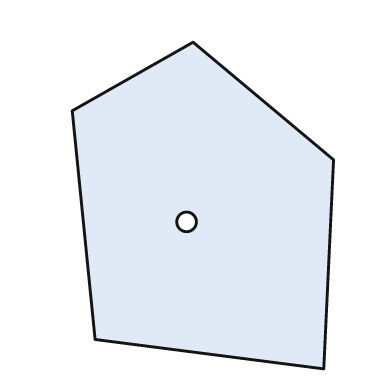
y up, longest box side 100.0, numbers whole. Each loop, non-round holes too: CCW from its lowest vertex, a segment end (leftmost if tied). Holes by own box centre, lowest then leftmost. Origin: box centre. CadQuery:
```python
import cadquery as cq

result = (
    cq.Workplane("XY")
    .moveTo(37.0, -50.0)
    .lineTo(40.0, 14.0)
    .lineTo(-3.0, 50.0)
    .lineTo(-40.0, 29.0)
    .lineTo(-33.0, -41.0)
    .close()
    .moveTo(-5.0, -5.0)
    .circle(3.0)
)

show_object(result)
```